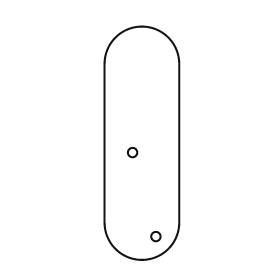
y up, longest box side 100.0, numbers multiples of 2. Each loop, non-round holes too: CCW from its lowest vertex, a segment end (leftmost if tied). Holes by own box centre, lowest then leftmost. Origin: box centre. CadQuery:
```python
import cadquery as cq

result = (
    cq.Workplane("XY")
    .moveTo(-16.0, -34.0)
    .threePointArc((0.0, -50.0), (16.0, -34.0))
    .lineTo(16.0, 34.0)
    .threePointArc((0.0, 50.0), (-16.0, 34.0))
    .close()
    .moveTo(6.0, -40.0)
    .circle(2.0)
    .moveTo(-4.0, -4.0)
    .circle(2.0)
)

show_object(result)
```